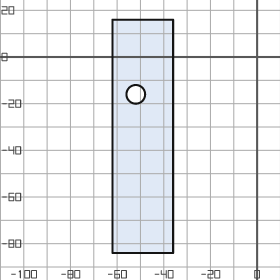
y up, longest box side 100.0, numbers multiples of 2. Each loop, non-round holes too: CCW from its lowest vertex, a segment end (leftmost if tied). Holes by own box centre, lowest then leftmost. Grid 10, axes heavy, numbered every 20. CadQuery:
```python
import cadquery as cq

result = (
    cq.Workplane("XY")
    .moveTo(-62.0, -84.0)
    .lineTo(-36.0, -84.0)
    .lineTo(-36.0, 16.0)
    .lineTo(-62.0, 16.0)
    .close()
    .moveTo(-52.0, -16.0)
    .circle(4.0)
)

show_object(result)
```